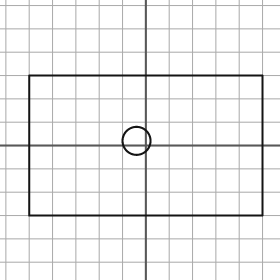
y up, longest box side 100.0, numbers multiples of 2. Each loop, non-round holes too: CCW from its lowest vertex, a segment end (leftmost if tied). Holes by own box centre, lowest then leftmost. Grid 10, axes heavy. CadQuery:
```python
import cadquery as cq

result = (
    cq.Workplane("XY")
    .moveTo(-50.0, -30.0)
    .lineTo(50.0, -30.0)
    .lineTo(50.0, 30.0)
    .lineTo(-50.0, 30.0)
    .close()
    .moveTo(-4.0, 2.0)
    .circle(6.0)
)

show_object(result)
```